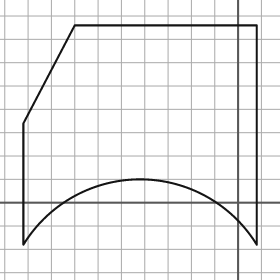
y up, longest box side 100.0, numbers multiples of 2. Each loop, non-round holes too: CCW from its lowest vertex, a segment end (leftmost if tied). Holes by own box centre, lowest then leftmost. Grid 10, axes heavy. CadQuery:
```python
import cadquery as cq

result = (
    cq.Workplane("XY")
    .moveTo(-92.0, -18.0)
    .threePointArc((-42.0, 10.0), (8.0, -18.0))
    .lineTo(8.0, 76.0)
    .lineTo(-70.0, 76.0)
    .lineTo(-92.0, 34.0)
    .close()
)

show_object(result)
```